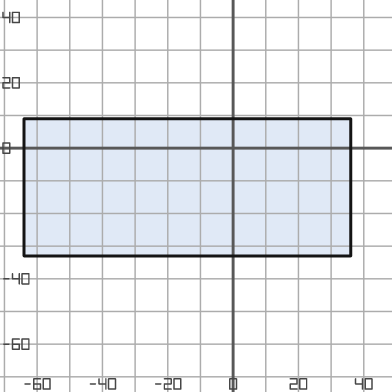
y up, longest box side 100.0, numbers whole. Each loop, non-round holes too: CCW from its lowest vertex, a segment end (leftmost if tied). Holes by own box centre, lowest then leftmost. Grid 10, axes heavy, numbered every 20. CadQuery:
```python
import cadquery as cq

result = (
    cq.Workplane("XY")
    .moveTo(-64.0, -33.0)
    .lineTo(36.0, -33.0)
    .lineTo(36.0, 9.0)
    .lineTo(-64.0, 9.0)
    .close()
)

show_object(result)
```